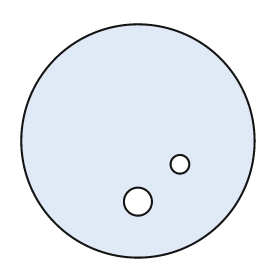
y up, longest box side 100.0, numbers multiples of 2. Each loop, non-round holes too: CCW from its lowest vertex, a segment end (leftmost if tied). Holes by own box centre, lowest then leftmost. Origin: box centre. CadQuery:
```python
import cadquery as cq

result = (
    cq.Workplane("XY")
    .moveTo(0.0, 0.0)
    .circle(50.0)
    .moveTo(0.0, -26.0)
    .circle(6.0)
    .moveTo(18.0, -10.0)
    .circle(4.0)
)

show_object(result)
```